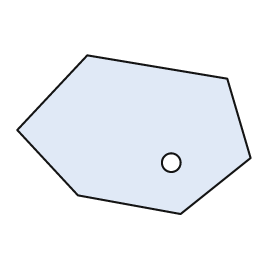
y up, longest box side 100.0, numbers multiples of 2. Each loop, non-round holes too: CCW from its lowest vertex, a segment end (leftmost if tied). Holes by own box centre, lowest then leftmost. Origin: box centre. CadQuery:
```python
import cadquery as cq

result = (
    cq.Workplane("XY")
    .moveTo(20.0, -34.0)
    .lineTo(50.0, -10.0)
    .lineTo(40.0, 24.0)
    .lineTo(-20.0, 34.0)
    .lineTo(-50.0, 2.0)
    .lineTo(-24.0, -26.0)
    .close()
    .moveTo(16.0, -12.0)
    .circle(4.0)
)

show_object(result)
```